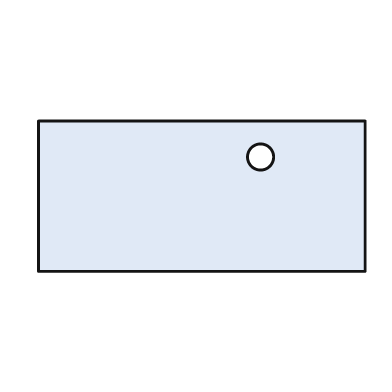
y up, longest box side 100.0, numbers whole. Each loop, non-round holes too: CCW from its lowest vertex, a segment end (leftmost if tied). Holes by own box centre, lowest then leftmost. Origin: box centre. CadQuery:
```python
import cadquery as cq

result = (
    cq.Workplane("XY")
    .moveTo(-50.0, -23.0)
    .lineTo(50.0, -23.0)
    .lineTo(50.0, 23.0)
    .lineTo(-50.0, 23.0)
    .close()
    .moveTo(18.0, 12.0)
    .circle(4.0)
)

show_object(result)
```